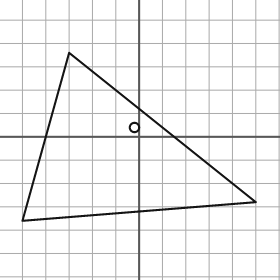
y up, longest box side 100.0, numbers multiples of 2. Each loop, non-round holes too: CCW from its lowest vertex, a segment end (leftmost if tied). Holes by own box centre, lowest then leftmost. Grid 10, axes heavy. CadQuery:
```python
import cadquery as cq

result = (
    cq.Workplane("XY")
    .moveTo(-50.0, -36.0)
    .lineTo(50.0, -28.0)
    .lineTo(-30.0, 36.0)
    .close()
    .moveTo(-2.0, 4.0)
    .circle(2.0)
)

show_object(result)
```